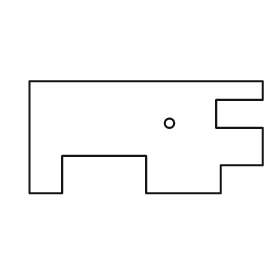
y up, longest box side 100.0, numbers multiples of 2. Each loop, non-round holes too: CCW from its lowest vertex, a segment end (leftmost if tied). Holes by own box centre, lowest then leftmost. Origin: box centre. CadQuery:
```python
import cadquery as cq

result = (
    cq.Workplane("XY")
    .moveTo(-50.0, -24.0)
    .lineTo(-36.0, -24.0)
    .lineTo(-36.0, -8.0)
    .lineTo(0.0, -8.0)
    .lineTo(0.0, -24.0)
    .lineTo(32.0, -24.0)
    .lineTo(32.0, -12.0)
    .lineTo(50.0, -12.0)
    .lineTo(50.0, 4.0)
    .lineTo(30.0, 4.0)
    .lineTo(30.0, 16.0)
    .lineTo(50.0, 16.0)
    .lineTo(50.0, 24.0)
    .lineTo(-50.0, 24.0)
    .close()
    .moveTo(10.0, 6.0)
    .circle(2.0)
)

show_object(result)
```